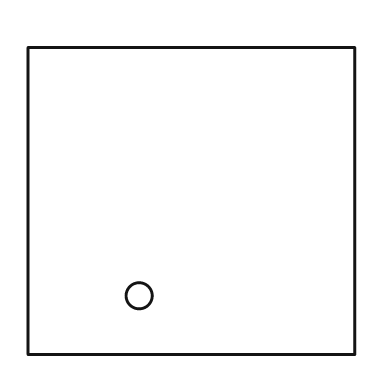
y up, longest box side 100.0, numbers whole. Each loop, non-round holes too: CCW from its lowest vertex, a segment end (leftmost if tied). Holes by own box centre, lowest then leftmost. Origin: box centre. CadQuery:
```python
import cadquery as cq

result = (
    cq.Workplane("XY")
    .moveTo(-50.0, -47.0)
    .lineTo(50.0, -47.0)
    .lineTo(50.0, 47.0)
    .lineTo(-50.0, 47.0)
    .close()
    .moveTo(-16.0, -29.0)
    .circle(4.0)
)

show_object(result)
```